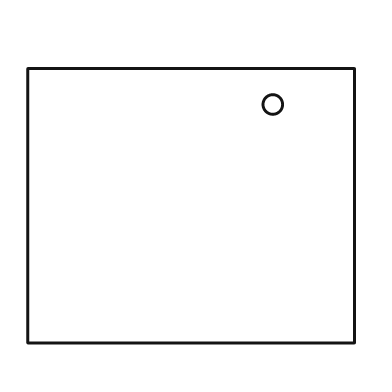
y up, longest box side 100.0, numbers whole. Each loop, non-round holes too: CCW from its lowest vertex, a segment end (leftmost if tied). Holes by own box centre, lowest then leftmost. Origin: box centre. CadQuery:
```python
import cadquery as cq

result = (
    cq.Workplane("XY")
    .moveTo(-50.0, -42.0)
    .lineTo(50.0, -42.0)
    .lineTo(50.0, 42.0)
    .lineTo(-50.0, 42.0)
    .close()
    .moveTo(25.0, 31.0)
    .circle(3.0)
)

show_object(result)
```